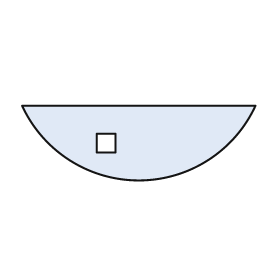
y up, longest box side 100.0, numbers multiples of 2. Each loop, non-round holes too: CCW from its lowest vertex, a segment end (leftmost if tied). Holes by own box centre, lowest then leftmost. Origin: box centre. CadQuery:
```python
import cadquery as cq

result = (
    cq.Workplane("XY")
    .moveTo(-50.0, 16.0)
    .threePointArc((0.0, -16.0), (50.0, 16.0))
    .close()
    .moveTo(-18.0, -4.0)
    .lineTo(-10.0, -4.0)
    .lineTo(-10.0, 4.0)
    .lineTo(-18.0, 4.0)
    .close()
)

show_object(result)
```